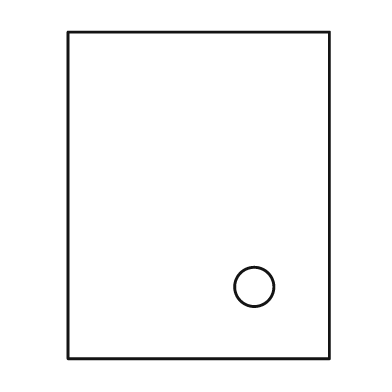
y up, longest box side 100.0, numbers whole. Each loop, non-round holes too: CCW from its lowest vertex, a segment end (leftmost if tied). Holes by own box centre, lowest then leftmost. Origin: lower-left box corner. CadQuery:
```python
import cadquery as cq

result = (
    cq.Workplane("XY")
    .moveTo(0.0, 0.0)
    .lineTo(80.0, 0.0)
    .lineTo(80.0, 100.0)
    .lineTo(0.0, 100.0)
    .close()
    .moveTo(57.0, 22.0)
    .circle(6.0)
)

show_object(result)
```